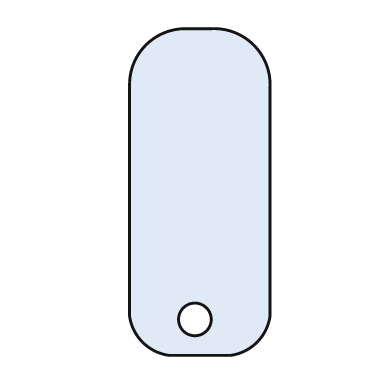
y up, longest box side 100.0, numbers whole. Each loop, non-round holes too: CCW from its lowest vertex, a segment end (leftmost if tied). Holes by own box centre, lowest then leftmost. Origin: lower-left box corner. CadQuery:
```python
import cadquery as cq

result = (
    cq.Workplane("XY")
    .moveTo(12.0, 0.0)
    .lineTo(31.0, 0.0)
    .threePointArc((39.0, 4.0), (43.0, 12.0))
    .lineTo(43.0, 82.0)
    .threePointArc((38.0, 95.0), (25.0, 100.0))
    .lineTo(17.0, 100.0)
    .threePointArc((5.0, 95.0), (0.0, 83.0))
    .lineTo(0.0, 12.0)
    .threePointArc((4.0, 4.0), (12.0, 0.0))
    .close()
    .moveTo(20.0, 11.0)
    .circle(5.0)
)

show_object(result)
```